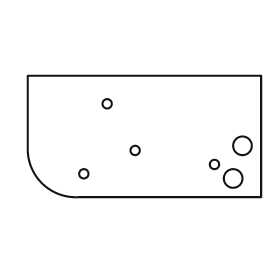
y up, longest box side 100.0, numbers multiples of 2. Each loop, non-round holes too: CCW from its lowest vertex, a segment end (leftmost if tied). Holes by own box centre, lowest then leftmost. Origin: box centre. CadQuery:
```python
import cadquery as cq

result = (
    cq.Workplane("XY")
    .moveTo(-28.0, -26.0)
    .lineTo(50.0, -26.0)
    .lineTo(50.0, 26.0)
    .lineTo(-50.0, 26.0)
    .lineTo(-50.0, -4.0)
    .threePointArc((-44.0, -20.0), (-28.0, -26.0))
    .close()
    .moveTo(38.0, -18.0)
    .circle(4.0)
    .moveTo(-26.0, -16.0)
    .circle(2.0)
    .moveTo(30.0, -12.0)
    .circle(2.0)
    .moveTo(-4.0, -6.0)
    .circle(2.0)
    .moveTo(42.0, -4.0)
    .circle(4.0)
    .moveTo(-16.0, 14.0)
    .circle(2.0)
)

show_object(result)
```